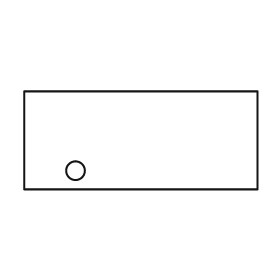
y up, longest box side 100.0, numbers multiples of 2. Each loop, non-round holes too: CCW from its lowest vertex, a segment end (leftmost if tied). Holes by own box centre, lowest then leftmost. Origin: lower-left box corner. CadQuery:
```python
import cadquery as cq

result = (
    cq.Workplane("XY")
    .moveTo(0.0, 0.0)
    .lineTo(100.0, 0.0)
    .lineTo(100.0, 42.0)
    .lineTo(0.0, 42.0)
    .close()
    .moveTo(22.0, 8.0)
    .circle(4.0)
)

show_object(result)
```